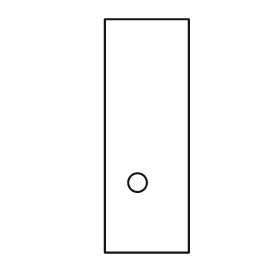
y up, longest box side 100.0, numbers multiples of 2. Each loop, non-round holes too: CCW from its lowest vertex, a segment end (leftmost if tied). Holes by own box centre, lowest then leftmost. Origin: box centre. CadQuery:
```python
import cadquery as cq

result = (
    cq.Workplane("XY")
    .moveTo(-18.0, -50.0)
    .lineTo(18.0, -50.0)
    .lineTo(18.0, 50.0)
    .lineTo(-18.0, 50.0)
    .close()
    .moveTo(-4.0, -20.0)
    .circle(4.0)
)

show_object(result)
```